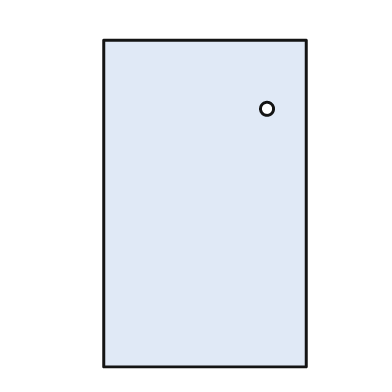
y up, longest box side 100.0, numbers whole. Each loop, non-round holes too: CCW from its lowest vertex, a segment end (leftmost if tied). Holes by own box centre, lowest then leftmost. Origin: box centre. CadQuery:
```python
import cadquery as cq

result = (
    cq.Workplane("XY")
    .moveTo(-31.0, -50.0)
    .lineTo(31.0, -50.0)
    .lineTo(31.0, 50.0)
    .lineTo(-31.0, 50.0)
    .close()
    .moveTo(19.0, 29.0)
    .circle(2.0)
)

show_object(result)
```